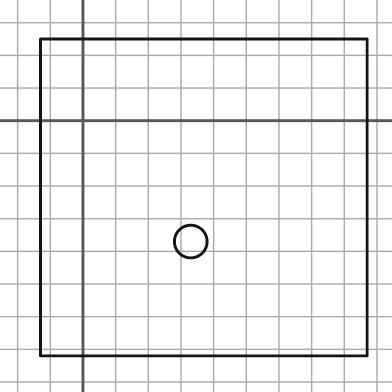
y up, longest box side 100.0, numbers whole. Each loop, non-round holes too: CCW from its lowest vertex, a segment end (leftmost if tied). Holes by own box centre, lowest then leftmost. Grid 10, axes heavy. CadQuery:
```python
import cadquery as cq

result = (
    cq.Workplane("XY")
    .moveTo(-13.0, -72.0)
    .lineTo(87.0, -72.0)
    .lineTo(87.0, 25.0)
    .lineTo(-13.0, 25.0)
    .close()
    .moveTo(33.0, -37.0)
    .circle(5.0)
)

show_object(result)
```